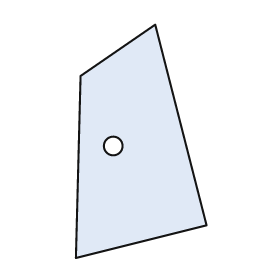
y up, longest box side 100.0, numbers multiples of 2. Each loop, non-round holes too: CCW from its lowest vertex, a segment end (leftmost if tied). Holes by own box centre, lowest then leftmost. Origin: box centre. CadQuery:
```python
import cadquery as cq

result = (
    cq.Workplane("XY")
    .moveTo(-28.0, -50.0)
    .lineTo(28.0, -36.0)
    .lineTo(6.0, 50.0)
    .lineTo(-26.0, 28.0)
    .close()
    .moveTo(-12.0, -2.0)
    .circle(4.0)
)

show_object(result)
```